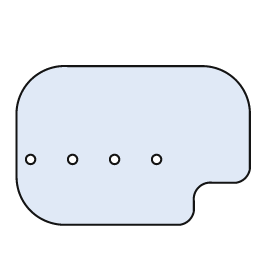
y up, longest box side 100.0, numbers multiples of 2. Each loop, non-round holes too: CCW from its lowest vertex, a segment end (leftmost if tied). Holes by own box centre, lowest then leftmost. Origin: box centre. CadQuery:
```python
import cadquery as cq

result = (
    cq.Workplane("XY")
    .moveTo(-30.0, -34.0)
    .lineTo(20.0, -34.0)
    .threePointArc((24.0, -32.0), (26.0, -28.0))
    .lineTo(26.0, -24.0)
    .threePointArc((28.0, -18.0), (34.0, -16.0))
    .lineTo(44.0, -16.0)
    .threePointArc((48.0, -14.0), (50.0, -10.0))
    .lineTo(50.0, 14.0)
    .threePointArc((44.0, 28.0), (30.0, 34.0))
    .lineTo(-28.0, 34.0)
    .threePointArc((-44.0, 28.0), (-50.0, 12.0))
    .lineTo(-50.0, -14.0)
    .threePointArc((-44.0, -28.0), (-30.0, -34.0))
    .close()
    .moveTo(-44.0, -6.0)
    .circle(2.0)
    .moveTo(-26.0, -6.0)
    .circle(2.0)
    .moveTo(-8.0, -6.0)
    .circle(2.0)
    .moveTo(10.0, -6.0)
    .circle(2.0)
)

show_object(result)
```